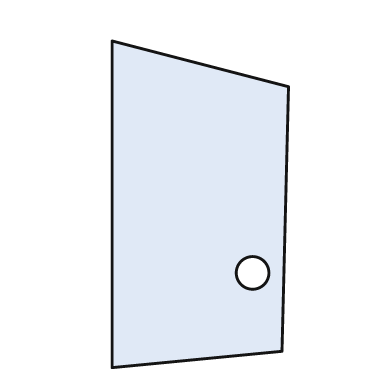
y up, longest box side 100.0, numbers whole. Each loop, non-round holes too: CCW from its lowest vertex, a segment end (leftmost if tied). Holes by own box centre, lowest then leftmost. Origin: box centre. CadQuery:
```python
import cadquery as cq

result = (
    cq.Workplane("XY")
    .moveTo(-27.0, -50.0)
    .lineTo(25.0, -45.0)
    .lineTo(27.0, 36.0)
    .lineTo(-27.0, 50.0)
    .close()
    .moveTo(16.0, -21.0)
    .circle(5.0)
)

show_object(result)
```